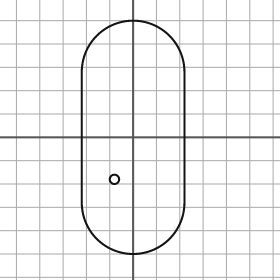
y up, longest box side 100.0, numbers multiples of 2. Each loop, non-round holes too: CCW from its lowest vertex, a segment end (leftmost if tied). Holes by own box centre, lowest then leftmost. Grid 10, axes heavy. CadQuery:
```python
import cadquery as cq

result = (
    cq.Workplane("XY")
    .moveTo(-22.0, -28.0)
    .threePointArc((0.0, -50.0), (22.0, -28.0))
    .lineTo(22.0, 28.0)
    .threePointArc((0.0, 50.0), (-22.0, 28.0))
    .close()
    .moveTo(-8.0, -18.0)
    .circle(2.0)
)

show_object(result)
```